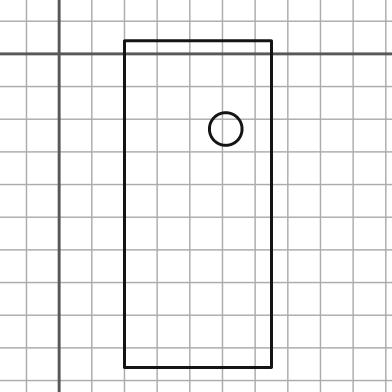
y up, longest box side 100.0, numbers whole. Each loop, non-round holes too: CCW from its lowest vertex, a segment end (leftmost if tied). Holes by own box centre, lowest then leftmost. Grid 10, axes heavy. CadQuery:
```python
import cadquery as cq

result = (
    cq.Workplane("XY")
    .moveTo(20.0, -96.0)
    .lineTo(65.0, -96.0)
    .lineTo(65.0, 4.0)
    .lineTo(20.0, 4.0)
    .close()
    .moveTo(51.0, -23.0)
    .circle(5.0)
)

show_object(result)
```